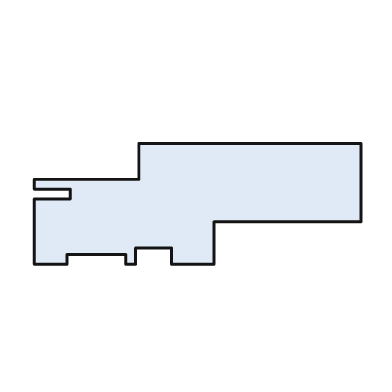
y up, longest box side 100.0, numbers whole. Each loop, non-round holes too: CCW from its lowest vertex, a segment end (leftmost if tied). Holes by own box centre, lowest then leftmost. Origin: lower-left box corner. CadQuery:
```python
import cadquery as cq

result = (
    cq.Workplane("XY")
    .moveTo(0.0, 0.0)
    .lineTo(10.0, 0.0)
    .lineTo(10.0, 3.0)
    .lineTo(28.0, 3.0)
    .lineTo(28.0, 0.0)
    .lineTo(31.0, 0.0)
    .lineTo(31.0, 5.0)
    .lineTo(42.0, 5.0)
    .lineTo(42.0, 0.0)
    .lineTo(55.0, 0.0)
    .lineTo(55.0, 13.0)
    .lineTo(100.0, 13.0)
    .lineTo(100.0, 37.0)
    .lineTo(32.0, 37.0)
    .lineTo(32.0, 26.0)
    .lineTo(0.0, 26.0)
    .lineTo(0.0, 23.0)
    .lineTo(11.0, 23.0)
    .lineTo(11.0, 20.0)
    .lineTo(0.0, 20.0)
    .close()
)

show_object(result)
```